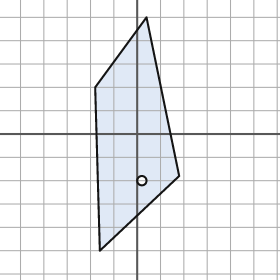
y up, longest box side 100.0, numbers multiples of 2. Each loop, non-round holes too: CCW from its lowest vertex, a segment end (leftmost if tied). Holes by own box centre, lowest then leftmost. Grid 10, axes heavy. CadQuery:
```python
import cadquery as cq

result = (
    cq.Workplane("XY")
    .moveTo(-16.0, -50.0)
    .lineTo(18.0, -18.0)
    .lineTo(4.0, 50.0)
    .lineTo(-18.0, 20.0)
    .close()
    .moveTo(2.0, -20.0)
    .circle(2.0)
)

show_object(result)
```